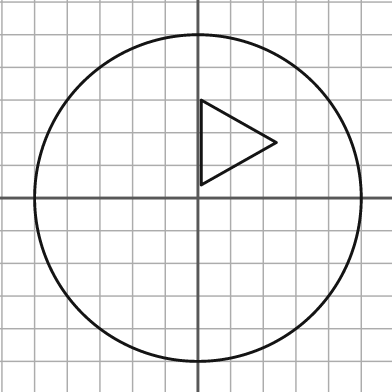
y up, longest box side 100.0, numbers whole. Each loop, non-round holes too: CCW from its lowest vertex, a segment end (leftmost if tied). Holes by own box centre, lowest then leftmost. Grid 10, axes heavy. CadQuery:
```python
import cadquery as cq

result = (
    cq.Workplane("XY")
    .moveTo(0.0, 0.0)
    .circle(50.0)
    .moveTo(1.0, 4.0)
    .lineTo(24.0, 17.0)
    .lineTo(1.0, 30.0)
    .close()
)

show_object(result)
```